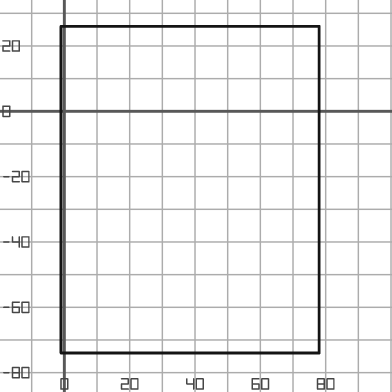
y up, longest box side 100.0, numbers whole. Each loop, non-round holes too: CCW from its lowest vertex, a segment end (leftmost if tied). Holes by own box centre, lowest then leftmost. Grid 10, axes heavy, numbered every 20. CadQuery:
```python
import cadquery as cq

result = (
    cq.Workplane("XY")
    .moveTo(-1.0, -74.0)
    .lineTo(78.0, -74.0)
    .lineTo(78.0, 26.0)
    .lineTo(-1.0, 26.0)
    .close()
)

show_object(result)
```